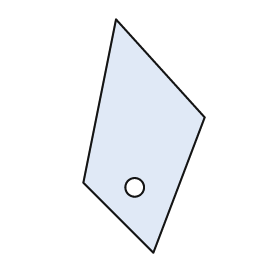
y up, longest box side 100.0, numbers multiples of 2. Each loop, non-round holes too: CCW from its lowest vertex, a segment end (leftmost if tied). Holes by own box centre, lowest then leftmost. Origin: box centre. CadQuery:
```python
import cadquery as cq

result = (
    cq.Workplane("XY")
    .moveTo(4.0, -50.0)
    .lineTo(26.0, 8.0)
    .lineTo(-12.0, 50.0)
    .lineTo(-26.0, -20.0)
    .close()
    .moveTo(-4.0, -22.0)
    .circle(4.0)
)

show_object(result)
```